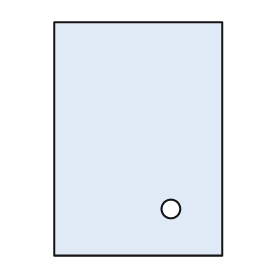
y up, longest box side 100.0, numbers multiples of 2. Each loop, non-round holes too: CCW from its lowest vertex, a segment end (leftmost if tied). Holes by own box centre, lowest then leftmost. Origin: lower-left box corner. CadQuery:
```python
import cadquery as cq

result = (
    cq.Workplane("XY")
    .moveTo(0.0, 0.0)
    .lineTo(72.0, 0.0)
    .lineTo(72.0, 100.0)
    .lineTo(0.0, 100.0)
    .close()
    .moveTo(50.0, 20.0)
    .circle(4.0)
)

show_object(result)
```